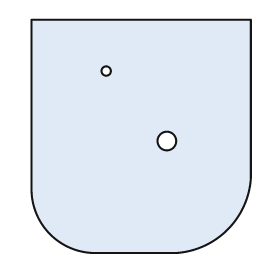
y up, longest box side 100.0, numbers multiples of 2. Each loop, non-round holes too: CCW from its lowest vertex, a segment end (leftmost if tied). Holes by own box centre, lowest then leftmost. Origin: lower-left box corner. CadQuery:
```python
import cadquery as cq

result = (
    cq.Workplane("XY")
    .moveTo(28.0, 0.0)
    .lineTo(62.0, 0.0)
    .threePointArc((84.0, 10.0), (94.0, 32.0))
    .lineTo(94.0, 100.0)
    .lineTo(0.0, 100.0)
    .lineTo(0.0, 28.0)
    .threePointArc((8.0, 8.0), (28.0, 0.0))
    .close()
    .moveTo(58.0, 48.0)
    .circle(4.0)
    .moveTo(32.0, 78.0)
    .circle(2.0)
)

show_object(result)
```